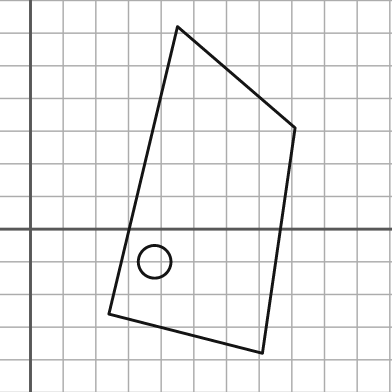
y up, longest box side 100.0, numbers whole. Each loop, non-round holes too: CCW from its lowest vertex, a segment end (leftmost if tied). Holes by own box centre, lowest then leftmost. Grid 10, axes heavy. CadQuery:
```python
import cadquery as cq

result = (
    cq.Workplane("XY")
    .moveTo(71.0, -38.0)
    .lineTo(81.0, 31.0)
    .lineTo(45.0, 62.0)
    .lineTo(24.0, -26.0)
    .close()
    .moveTo(38.0, -10.0)
    .circle(5.0)
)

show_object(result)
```